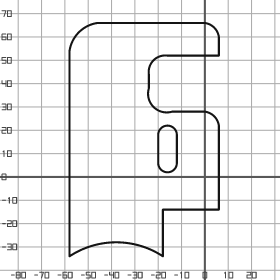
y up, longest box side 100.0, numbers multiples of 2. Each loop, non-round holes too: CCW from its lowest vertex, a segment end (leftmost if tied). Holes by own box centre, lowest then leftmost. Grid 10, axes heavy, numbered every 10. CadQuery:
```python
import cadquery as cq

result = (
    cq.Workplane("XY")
    .moveTo(-58.0, -34.0)
    .threePointArc((-38.0, -28.0), (-18.0, -34.0))
    .lineTo(-18.0, -14.0)
    .lineTo(6.0, -14.0)
    .lineTo(6.0, 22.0)
    .threePointArc((4.0, 26.0), (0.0, 28.0))
    .lineTo(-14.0, 28.0)
    .threePointArc((-22.0, 30.0), (-24.0, 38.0))
    .lineTo(-24.0, 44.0)
    .threePointArc((-22.0, 50.0), (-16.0, 52.0))
    .lineTo(6.0, 52.0)
    .lineTo(6.0, 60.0)
    .threePointArc((4.0, 64.0), (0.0, 66.0))
    .lineTo(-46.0, 66.0)
    .threePointArc((-54.0, 62.0), (-58.0, 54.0))
    .close()
    .moveTo(-20.0, 6.0)
    .threePointArc((-16.0, 2.0), (-12.0, 6.0))
    .lineTo(-12.0, 18.0)
    .threePointArc((-16.0, 22.0), (-20.0, 18.0))
    .close()
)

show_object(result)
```